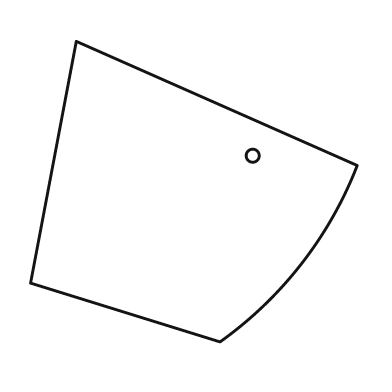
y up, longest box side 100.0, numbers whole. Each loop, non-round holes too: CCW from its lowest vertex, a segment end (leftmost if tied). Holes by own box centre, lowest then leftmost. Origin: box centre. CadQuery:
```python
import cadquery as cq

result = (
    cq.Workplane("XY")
    .moveTo(8.0, -46.0)
    .threePointArc((33.0, -22.0), (50.0, 8.0))
    .lineTo(-36.0, 46.0)
    .lineTo(-50.0, -28.0)
    .close()
    .moveTo(18.0, 11.0)
    .circle(2.0)
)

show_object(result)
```